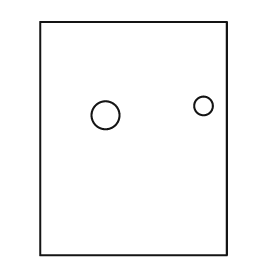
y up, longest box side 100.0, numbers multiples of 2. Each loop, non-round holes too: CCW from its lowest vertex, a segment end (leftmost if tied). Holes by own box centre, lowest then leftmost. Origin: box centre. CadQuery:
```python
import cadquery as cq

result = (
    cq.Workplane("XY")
    .moveTo(-40.0, -50.0)
    .lineTo(40.0, -50.0)
    .lineTo(40.0, 50.0)
    .lineTo(-40.0, 50.0)
    .close()
    .moveTo(-12.0, 10.0)
    .circle(6.0)
    .moveTo(30.0, 14.0)
    .circle(4.0)
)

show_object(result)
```